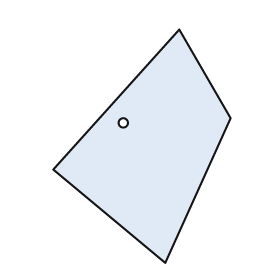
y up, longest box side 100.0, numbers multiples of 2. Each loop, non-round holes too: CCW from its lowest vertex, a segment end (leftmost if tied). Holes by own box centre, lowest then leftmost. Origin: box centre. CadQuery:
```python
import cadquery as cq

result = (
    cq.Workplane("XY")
    .moveTo(10.0, -50.0)
    .lineTo(38.0, 12.0)
    .lineTo(16.0, 50.0)
    .lineTo(-38.0, -10.0)
    .close()
    .moveTo(-8.0, 10.0)
    .circle(2.0)
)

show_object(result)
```